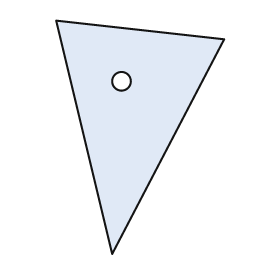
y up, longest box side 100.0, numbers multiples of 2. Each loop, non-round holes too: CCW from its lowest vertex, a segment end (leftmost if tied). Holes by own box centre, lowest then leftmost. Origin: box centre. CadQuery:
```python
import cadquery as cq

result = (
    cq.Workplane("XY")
    .moveTo(-12.0, -50.0)
    .lineTo(36.0, 42.0)
    .lineTo(-36.0, 50.0)
    .close()
    .moveTo(-8.0, 24.0)
    .circle(4.0)
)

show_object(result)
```